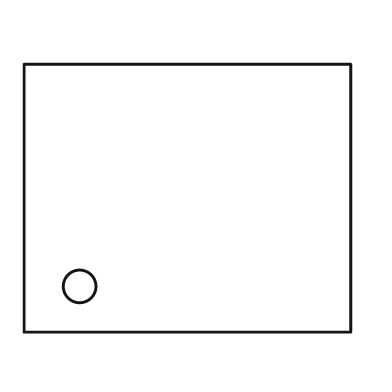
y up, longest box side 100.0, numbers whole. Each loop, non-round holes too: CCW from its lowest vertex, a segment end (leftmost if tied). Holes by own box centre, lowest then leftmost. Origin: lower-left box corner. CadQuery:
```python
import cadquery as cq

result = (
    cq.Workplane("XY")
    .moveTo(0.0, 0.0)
    .lineTo(100.0, 0.0)
    .lineTo(100.0, 82.0)
    .lineTo(0.0, 82.0)
    .close()
    .moveTo(17.0, 14.0)
    .circle(5.0)
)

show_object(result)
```